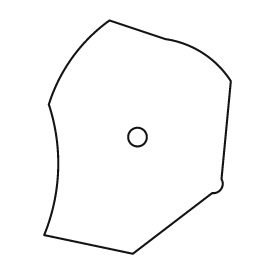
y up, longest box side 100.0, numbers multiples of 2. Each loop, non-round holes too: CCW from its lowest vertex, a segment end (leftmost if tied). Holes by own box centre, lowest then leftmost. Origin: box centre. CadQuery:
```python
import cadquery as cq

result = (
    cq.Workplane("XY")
    .moveTo(-2.0, -50.0)
    .lineTo(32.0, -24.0)
    .threePointArc((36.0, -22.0), (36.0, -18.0))
    .lineTo(40.0, 24.0)
    .threePointArc((28.0, 36.0), (12.0, 42.0))
    .lineTo(-12.0, 50.0)
    .threePointArc((-28.0, 34.0), (-38.0, 14.0))
    .threePointArc((-34.0, -14.0), (-40.0, -42.0))
    .close()
    .moveTo(0.0, 0.0)
    .circle(4.0)
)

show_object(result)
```